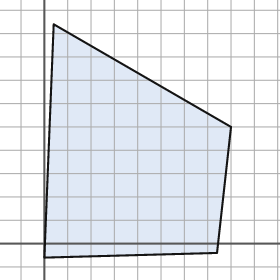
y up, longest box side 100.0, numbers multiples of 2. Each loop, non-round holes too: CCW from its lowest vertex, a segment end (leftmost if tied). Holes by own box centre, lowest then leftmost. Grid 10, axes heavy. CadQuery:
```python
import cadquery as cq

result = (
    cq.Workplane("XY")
    .moveTo(0.0, -6.0)
    .lineTo(74.0, -4.0)
    .lineTo(80.0, 50.0)
    .lineTo(4.0, 94.0)
    .close()
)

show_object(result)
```